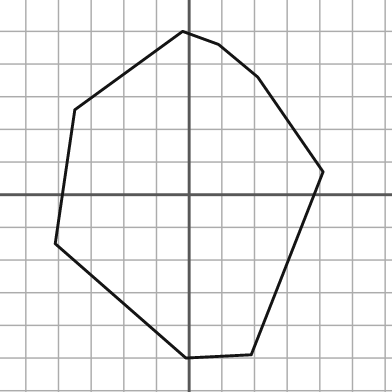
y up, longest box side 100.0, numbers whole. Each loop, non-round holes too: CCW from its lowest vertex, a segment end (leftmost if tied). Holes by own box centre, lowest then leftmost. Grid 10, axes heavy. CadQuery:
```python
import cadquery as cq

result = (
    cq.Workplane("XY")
    .moveTo(-1.0, -50.0)
    .lineTo(19.0, -49.0)
    .lineTo(41.0, 7.0)
    .lineTo(21.0, 36.0)
    .lineTo(9.0, 46.0)
    .lineTo(-2.0, 50.0)
    .lineTo(-35.0, 26.0)
    .lineTo(-41.0, -15.0)
    .close()
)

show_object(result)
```